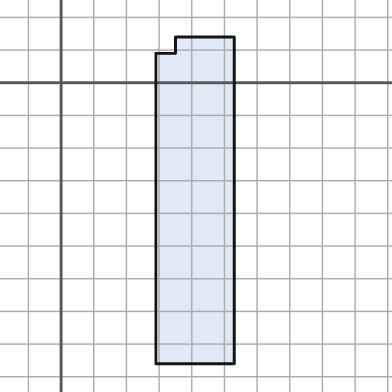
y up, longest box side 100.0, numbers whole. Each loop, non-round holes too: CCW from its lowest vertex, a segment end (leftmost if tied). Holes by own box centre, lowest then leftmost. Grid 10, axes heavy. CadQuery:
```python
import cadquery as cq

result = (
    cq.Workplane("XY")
    .moveTo(29.0, -86.0)
    .lineTo(53.0, -86.0)
    .lineTo(53.0, 14.0)
    .lineTo(35.0, 14.0)
    .lineTo(35.0, 9.0)
    .lineTo(29.0, 9.0)
    .close()
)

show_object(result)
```